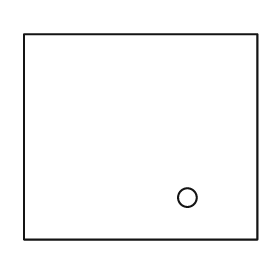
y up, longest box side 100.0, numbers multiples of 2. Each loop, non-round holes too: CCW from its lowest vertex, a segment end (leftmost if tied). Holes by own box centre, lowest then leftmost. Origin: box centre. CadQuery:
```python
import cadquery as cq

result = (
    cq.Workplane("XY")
    .moveTo(-50.0, -44.0)
    .lineTo(50.0, -44.0)
    .lineTo(50.0, 44.0)
    .lineTo(-50.0, 44.0)
    .close()
    .moveTo(20.0, -26.0)
    .circle(4.0)
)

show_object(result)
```